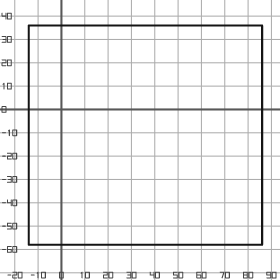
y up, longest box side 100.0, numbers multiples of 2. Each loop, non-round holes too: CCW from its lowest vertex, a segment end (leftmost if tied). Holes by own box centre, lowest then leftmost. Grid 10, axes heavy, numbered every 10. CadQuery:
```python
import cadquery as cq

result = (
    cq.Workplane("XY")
    .moveTo(-14.0, -58.0)
    .lineTo(86.0, -58.0)
    .lineTo(86.0, 36.0)
    .lineTo(-14.0, 36.0)
    .close()
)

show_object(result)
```